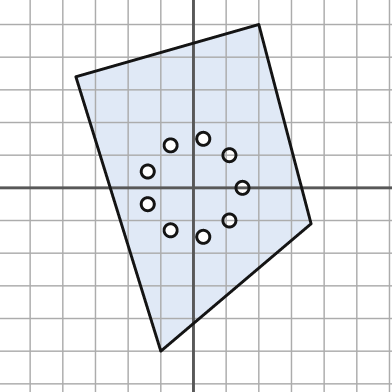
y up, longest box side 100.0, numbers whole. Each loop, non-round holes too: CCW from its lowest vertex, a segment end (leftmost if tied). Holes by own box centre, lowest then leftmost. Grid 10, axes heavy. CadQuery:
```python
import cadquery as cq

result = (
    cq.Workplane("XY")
    .moveTo(-10.0, -50.0)
    .lineTo(36.0, -11.0)
    .lineTo(20.0, 50.0)
    .lineTo(-36.0, 34.0)
    .close()
    .moveTo(3.0, -15.0)
    .circle(2.0)
    .moveTo(-7.0, -13.0)
    .circle(2.0)
    .moveTo(11.0, -10.0)
    .circle(2.0)
    .moveTo(-14.0, -5.0)
    .circle(2.0)
    .moveTo(15.0, 0.0)
    .circle(2.0)
    .moveTo(-14.0, 5.0)
    .circle(2.0)
    .moveTo(11.0, 10.0)
    .circle(2.0)
    .moveTo(-7.0, 13.0)
    .circle(2.0)
    .moveTo(3.0, 15.0)
    .circle(2.0)
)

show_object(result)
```